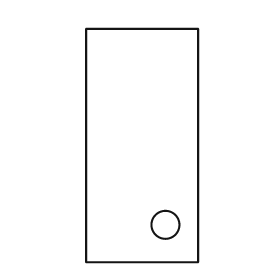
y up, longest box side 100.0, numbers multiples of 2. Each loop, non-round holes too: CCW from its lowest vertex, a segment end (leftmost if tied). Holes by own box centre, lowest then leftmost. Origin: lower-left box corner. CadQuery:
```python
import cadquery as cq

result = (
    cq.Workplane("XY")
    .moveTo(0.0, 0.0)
    .lineTo(48.0, 0.0)
    .lineTo(48.0, 100.0)
    .lineTo(0.0, 100.0)
    .close()
    .moveTo(34.0, 16.0)
    .circle(6.0)
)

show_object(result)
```